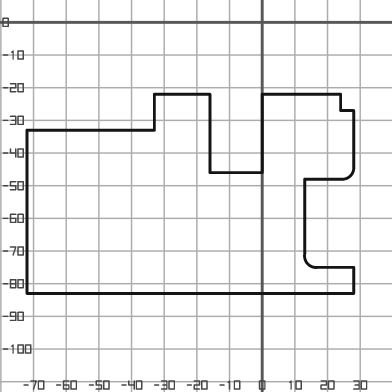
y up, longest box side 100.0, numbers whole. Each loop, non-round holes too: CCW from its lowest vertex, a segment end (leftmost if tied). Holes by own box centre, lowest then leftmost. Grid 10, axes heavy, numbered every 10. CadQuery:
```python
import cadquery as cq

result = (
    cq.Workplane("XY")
    .moveTo(-72.0, -83.0)
    .lineTo(28.0, -83.0)
    .lineTo(28.0, -75.0)
    .lineTo(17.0, -75.0)
    .threePointArc((14.0, -74.0), (13.0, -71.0))
    .lineTo(13.0, -48.0)
    .lineTo(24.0, -48.0)
    .threePointArc((27.0, -47.0), (28.0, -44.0))
    .lineTo(28.0, -27.0)
    .lineTo(24.0, -27.0)
    .lineTo(24.0, -22.0)
    .lineTo(0.0, -22.0)
    .lineTo(0.0, -46.0)
    .lineTo(-16.0, -46.0)
    .lineTo(-16.0, -22.0)
    .lineTo(-33.0, -22.0)
    .lineTo(-33.0, -33.0)
    .lineTo(-72.0, -33.0)
    .close()
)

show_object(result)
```